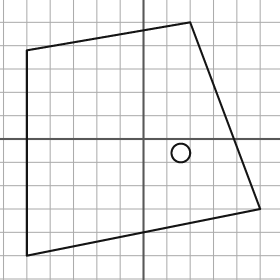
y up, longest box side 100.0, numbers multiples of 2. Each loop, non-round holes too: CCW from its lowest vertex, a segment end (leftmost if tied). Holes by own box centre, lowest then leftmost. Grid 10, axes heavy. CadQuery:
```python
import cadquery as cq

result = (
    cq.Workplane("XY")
    .moveTo(-50.0, -50.0)
    .lineTo(50.0, -30.0)
    .lineTo(20.0, 50.0)
    .lineTo(-50.0, 38.0)
    .close()
    .moveTo(16.0, -6.0)
    .circle(4.0)
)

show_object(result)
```